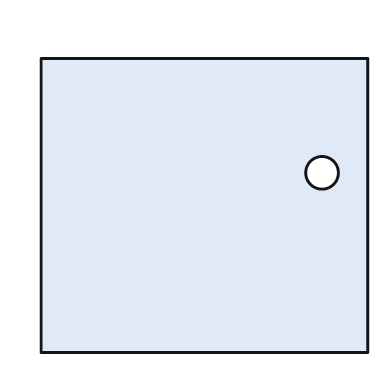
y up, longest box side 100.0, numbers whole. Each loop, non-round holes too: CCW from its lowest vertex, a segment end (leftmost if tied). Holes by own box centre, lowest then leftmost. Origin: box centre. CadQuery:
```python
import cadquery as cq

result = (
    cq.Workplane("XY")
    .moveTo(-50.0, -45.0)
    .lineTo(50.0, -45.0)
    .lineTo(50.0, 45.0)
    .lineTo(-50.0, 45.0)
    .close()
    .moveTo(36.0, 10.0)
    .circle(5.0)
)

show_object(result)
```